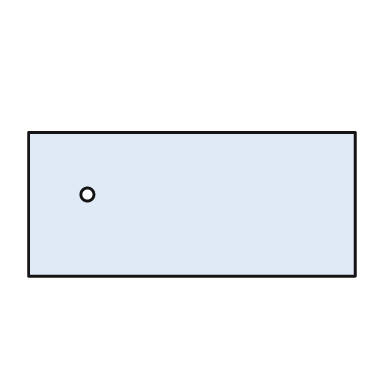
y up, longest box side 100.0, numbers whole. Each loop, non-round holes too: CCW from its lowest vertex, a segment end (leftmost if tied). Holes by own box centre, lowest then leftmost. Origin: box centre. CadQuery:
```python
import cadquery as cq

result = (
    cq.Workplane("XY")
    .moveTo(-50.0, -22.0)
    .lineTo(50.0, -22.0)
    .lineTo(50.0, 22.0)
    .lineTo(-50.0, 22.0)
    .close()
    .moveTo(-32.0, 3.0)
    .circle(2.0)
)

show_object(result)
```